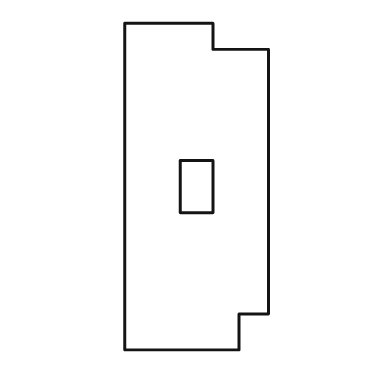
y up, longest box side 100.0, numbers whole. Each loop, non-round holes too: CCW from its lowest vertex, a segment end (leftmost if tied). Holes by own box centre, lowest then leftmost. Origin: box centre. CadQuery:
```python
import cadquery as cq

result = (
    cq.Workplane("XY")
    .moveTo(-22.0, -50.0)
    .lineTo(13.0, -50.0)
    .lineTo(13.0, -39.0)
    .lineTo(22.0, -39.0)
    .lineTo(22.0, 42.0)
    .lineTo(5.0, 42.0)
    .lineTo(5.0, 50.0)
    .lineTo(-22.0, 50.0)
    .close()
    .moveTo(-5.0, -8.0)
    .lineTo(5.0, -8.0)
    .lineTo(5.0, 8.0)
    .lineTo(-5.0, 8.0)
    .close()
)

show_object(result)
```